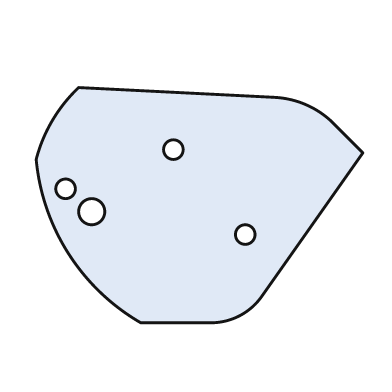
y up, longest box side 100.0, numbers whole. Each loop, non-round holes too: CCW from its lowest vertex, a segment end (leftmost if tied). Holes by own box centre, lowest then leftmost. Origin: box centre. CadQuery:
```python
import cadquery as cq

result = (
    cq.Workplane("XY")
    .moveTo(-18.0, -36.0)
    .lineTo(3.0, -36.0)
    .threePointArc((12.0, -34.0), (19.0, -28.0))
    .lineTo(50.0, 16.0)
    .lineTo(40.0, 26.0)
    .threePointArc((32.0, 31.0), (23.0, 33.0))
    .lineTo(-37.0, 36.0)
    .threePointArc((-45.0, 26.0), (-50.0, 14.0))
    .threePointArc((-40.0, -15.0), (-18.0, -36.0))
    .close()
    .moveTo(14.0, -9.0)
    .circle(3.0)
    .moveTo(-33.0, -2.0)
    .circle(4.0)
    .moveTo(-41.0, 5.0)
    .circle(3.0)
    .moveTo(-8.0, 17.0)
    .circle(3.0)
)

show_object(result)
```